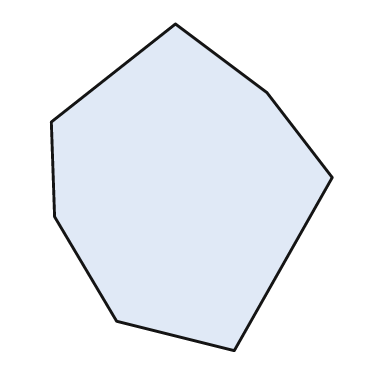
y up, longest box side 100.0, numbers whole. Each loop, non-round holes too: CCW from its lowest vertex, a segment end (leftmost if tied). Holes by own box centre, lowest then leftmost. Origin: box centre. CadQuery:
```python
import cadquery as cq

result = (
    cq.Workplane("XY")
    .moveTo(13.0, -50.0)
    .lineTo(43.0, 3.0)
    .lineTo(23.0, 29.0)
    .lineTo(-5.0, 50.0)
    .lineTo(-43.0, 20.0)
    .lineTo(-42.0, -9.0)
    .lineTo(-23.0, -41.0)
    .close()
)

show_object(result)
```